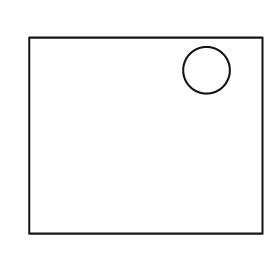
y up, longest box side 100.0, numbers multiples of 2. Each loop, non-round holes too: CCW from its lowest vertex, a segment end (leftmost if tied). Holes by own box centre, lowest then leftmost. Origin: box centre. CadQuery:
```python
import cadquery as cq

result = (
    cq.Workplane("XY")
    .moveTo(-50.0, -42.0)
    .lineTo(50.0, -42.0)
    .lineTo(50.0, 42.0)
    .lineTo(-50.0, 42.0)
    .close()
    .moveTo(26.0, 28.0)
    .circle(10.0)
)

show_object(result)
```